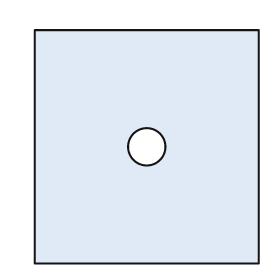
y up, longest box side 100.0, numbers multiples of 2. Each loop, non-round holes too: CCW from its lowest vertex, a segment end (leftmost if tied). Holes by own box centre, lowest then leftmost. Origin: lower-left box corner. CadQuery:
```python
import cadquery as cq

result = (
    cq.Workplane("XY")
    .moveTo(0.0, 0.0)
    .lineTo(96.0, 0.0)
    .lineTo(96.0, 100.0)
    .lineTo(0.0, 100.0)
    .close()
    .moveTo(48.0, 50.0)
    .circle(8.0)
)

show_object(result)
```